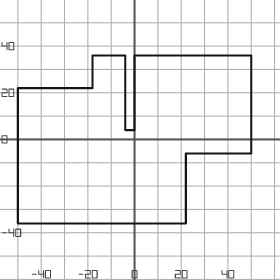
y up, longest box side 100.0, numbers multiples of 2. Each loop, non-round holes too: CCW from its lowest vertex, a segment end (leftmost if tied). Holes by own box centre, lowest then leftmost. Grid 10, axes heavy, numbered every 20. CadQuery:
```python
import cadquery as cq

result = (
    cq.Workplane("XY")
    .moveTo(-50.0, -36.0)
    .lineTo(22.0, -36.0)
    .lineTo(22.0, -6.0)
    .lineTo(50.0, -6.0)
    .lineTo(50.0, 36.0)
    .lineTo(0.0, 36.0)
    .lineTo(0.0, 4.0)
    .lineTo(-4.0, 4.0)
    .lineTo(-4.0, 36.0)
    .lineTo(-18.0, 36.0)
    .lineTo(-18.0, 22.0)
    .lineTo(-50.0, 22.0)
    .close()
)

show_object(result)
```